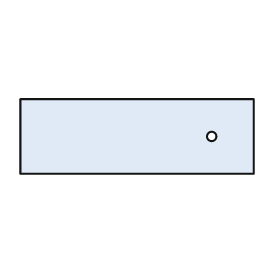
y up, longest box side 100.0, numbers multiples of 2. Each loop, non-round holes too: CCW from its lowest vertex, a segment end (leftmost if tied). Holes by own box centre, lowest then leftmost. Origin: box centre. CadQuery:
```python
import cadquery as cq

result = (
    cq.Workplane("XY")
    .moveTo(-50.0, -16.0)
    .lineTo(50.0, -16.0)
    .lineTo(50.0, 16.0)
    .lineTo(-50.0, 16.0)
    .close()
    .moveTo(32.0, 0.0)
    .circle(2.0)
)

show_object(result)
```